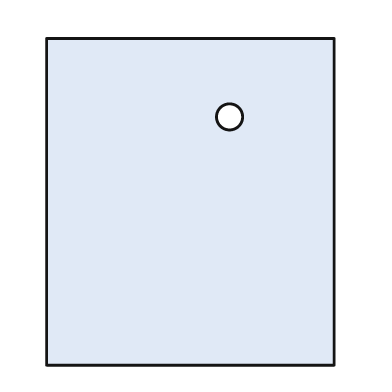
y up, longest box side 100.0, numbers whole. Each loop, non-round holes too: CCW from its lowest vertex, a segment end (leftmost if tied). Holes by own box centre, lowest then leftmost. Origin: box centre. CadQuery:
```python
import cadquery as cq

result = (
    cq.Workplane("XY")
    .moveTo(-44.0, -50.0)
    .lineTo(44.0, -50.0)
    .lineTo(44.0, 50.0)
    .lineTo(-44.0, 50.0)
    .close()
    .moveTo(12.0, 26.0)
    .circle(4.0)
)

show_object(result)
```